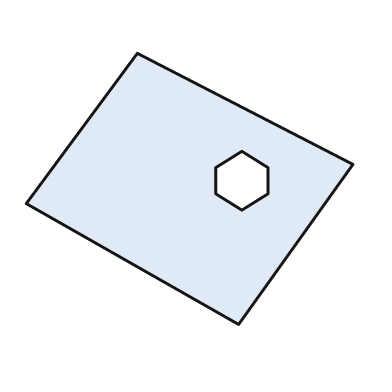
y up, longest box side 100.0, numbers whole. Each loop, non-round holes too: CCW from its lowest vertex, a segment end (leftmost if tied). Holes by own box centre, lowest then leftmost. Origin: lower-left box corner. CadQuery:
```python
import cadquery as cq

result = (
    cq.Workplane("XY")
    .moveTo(65.0, 0.0)
    .lineTo(100.0, 49.0)
    .lineTo(34.0, 83.0)
    .lineTo(0.0, 37.0)
    .close()
    .moveTo(66.0, 35.0)
    .lineTo(74.0, 40.0)
    .lineTo(74.0, 48.0)
    .lineTo(66.0, 53.0)
    .lineTo(58.0, 48.0)
    .lineTo(58.0, 40.0)
    .close()
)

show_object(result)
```